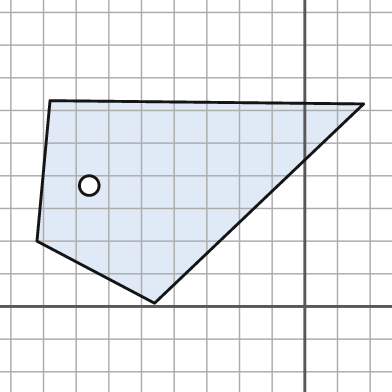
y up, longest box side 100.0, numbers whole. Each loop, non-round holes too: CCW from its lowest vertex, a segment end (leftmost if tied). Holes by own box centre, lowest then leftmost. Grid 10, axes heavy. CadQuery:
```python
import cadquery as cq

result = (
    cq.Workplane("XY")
    .moveTo(-46.0, 1.0)
    .lineTo(18.0, 62.0)
    .lineTo(-78.0, 63.0)
    .lineTo(-82.0, 20.0)
    .close()
    .moveTo(-66.0, 37.0)
    .circle(3.0)
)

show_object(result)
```